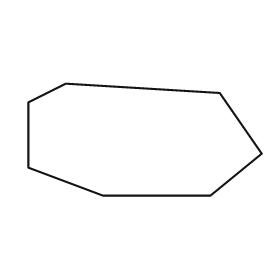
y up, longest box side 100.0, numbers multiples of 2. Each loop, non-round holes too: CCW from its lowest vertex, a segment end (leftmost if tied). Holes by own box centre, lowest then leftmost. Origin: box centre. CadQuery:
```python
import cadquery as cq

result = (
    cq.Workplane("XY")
    .moveTo(-18.0, -24.0)
    .lineTo(28.0, -24.0)
    .lineTo(50.0, -6.0)
    .lineTo(32.0, 20.0)
    .lineTo(-34.0, 24.0)
    .lineTo(-50.0, 16.0)
    .lineTo(-50.0, -12.0)
    .close()
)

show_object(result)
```